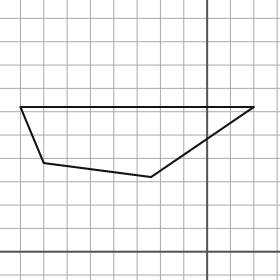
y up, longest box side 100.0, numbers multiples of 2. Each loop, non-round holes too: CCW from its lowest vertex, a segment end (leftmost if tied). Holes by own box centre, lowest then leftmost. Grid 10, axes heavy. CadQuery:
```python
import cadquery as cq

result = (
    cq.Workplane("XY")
    .moveTo(-24.0, 32.0)
    .lineTo(20.0, 62.0)
    .lineTo(-80.0, 62.0)
    .lineTo(-70.0, 38.0)
    .close()
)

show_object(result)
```